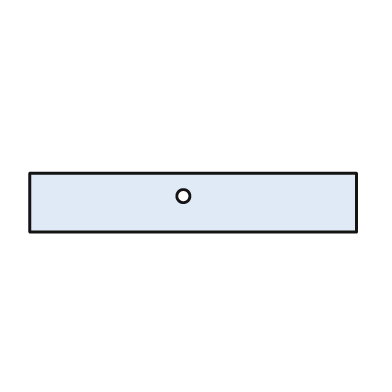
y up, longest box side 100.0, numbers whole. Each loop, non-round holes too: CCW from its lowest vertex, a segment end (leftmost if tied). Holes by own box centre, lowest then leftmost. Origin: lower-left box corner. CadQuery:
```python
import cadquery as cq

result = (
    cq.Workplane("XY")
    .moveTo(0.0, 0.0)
    .lineTo(100.0, 0.0)
    .lineTo(100.0, 18.0)
    .lineTo(0.0, 18.0)
    .close()
    .moveTo(47.0, 11.0)
    .circle(2.0)
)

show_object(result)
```